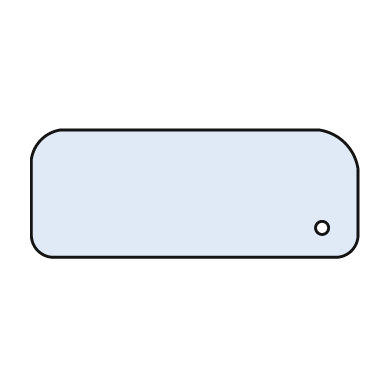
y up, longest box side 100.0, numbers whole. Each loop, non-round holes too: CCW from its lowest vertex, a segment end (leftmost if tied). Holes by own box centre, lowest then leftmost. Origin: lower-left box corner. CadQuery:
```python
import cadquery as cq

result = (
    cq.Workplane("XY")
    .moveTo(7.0, 0.0)
    .lineTo(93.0, 0.0)
    .threePointArc((98.0, 2.0), (100.0, 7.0))
    .lineTo(100.0, 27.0)
    .threePointArc((96.0, 35.0), (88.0, 39.0))
    .lineTo(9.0, 39.0)
    .threePointArc((3.0, 36.0), (0.0, 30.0))
    .lineTo(0.0, 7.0)
    .threePointArc((2.0, 2.0), (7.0, 0.0))
    .close()
    .moveTo(89.0, 9.0)
    .circle(2.0)
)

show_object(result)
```